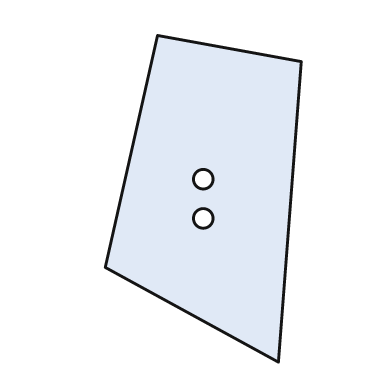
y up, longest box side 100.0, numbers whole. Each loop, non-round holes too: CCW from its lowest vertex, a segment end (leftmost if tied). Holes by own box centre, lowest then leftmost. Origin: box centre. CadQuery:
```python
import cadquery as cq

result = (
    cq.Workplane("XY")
    .moveTo(23.0, -50.0)
    .lineTo(30.0, 42.0)
    .lineTo(-14.0, 50.0)
    .lineTo(-30.0, -21.0)
    .close()
    .moveTo(0.0, -6.0)
    .circle(3.0)
    .moveTo(0.0, 6.0)
    .circle(3.0)
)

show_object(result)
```